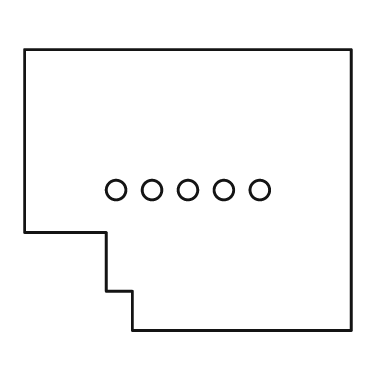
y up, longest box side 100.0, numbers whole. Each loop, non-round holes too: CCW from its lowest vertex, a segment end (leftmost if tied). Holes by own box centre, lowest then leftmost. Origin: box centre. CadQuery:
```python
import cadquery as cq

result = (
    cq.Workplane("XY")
    .moveTo(-17.0, -43.0)
    .lineTo(50.0, -43.0)
    .lineTo(50.0, 43.0)
    .lineTo(-50.0, 43.0)
    .lineTo(-50.0, -13.0)
    .lineTo(-25.0, -13.0)
    .lineTo(-25.0, -31.0)
    .lineTo(-17.0, -31.0)
    .close()
    .moveTo(-22.0, 0.0)
    .circle(3.0)
    .moveTo(-11.0, 0.0)
    .circle(3.0)
    .moveTo(0.0, 0.0)
    .circle(3.0)
    .moveTo(11.0, 0.0)
    .circle(3.0)
    .moveTo(22.0, 0.0)
    .circle(3.0)
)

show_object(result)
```